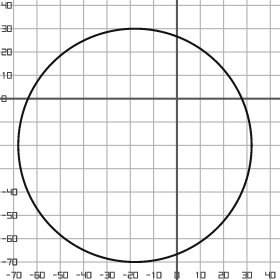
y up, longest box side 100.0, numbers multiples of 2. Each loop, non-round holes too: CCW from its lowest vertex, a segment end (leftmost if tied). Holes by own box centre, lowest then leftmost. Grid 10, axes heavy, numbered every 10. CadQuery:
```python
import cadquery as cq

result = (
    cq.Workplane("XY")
    .moveTo(-18.0, -20.0)
    .circle(50.0)
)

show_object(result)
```